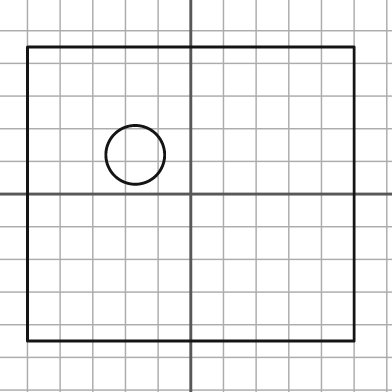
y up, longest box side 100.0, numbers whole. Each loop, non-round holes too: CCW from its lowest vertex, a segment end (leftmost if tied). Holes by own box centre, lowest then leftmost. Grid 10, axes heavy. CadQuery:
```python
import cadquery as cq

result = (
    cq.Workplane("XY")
    .moveTo(-50.0, -45.0)
    .lineTo(50.0, -45.0)
    .lineTo(50.0, 45.0)
    .lineTo(-50.0, 45.0)
    .close()
    .moveTo(-17.0, 12.0)
    .circle(9.0)
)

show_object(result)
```